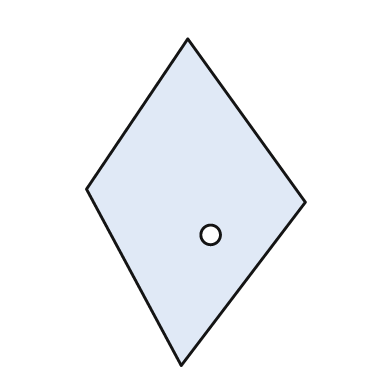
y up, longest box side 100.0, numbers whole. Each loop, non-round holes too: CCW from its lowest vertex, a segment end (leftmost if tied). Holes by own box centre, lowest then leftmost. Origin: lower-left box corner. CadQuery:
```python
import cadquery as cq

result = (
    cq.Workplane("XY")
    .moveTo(29.0, 0.0)
    .lineTo(67.0, 50.0)
    .lineTo(31.0, 100.0)
    .lineTo(0.0, 54.0)
    .close()
    .moveTo(38.0, 40.0)
    .circle(3.0)
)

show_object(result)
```